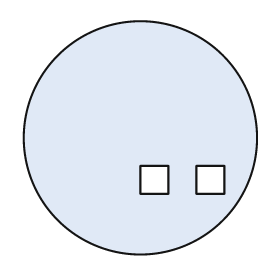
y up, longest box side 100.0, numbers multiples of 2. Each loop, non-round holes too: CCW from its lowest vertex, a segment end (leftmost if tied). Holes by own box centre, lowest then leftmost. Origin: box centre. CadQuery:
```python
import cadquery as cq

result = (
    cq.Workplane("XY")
    .moveTo(0.0, 0.0)
    .circle(50.0)
    .moveTo(0.0, -24.0)
    .lineTo(12.0, -24.0)
    .lineTo(12.0, -12.0)
    .lineTo(0.0, -12.0)
    .close()
    .moveTo(24.0, -24.0)
    .lineTo(36.0, -24.0)
    .lineTo(36.0, -12.0)
    .lineTo(24.0, -12.0)
    .close()
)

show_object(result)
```